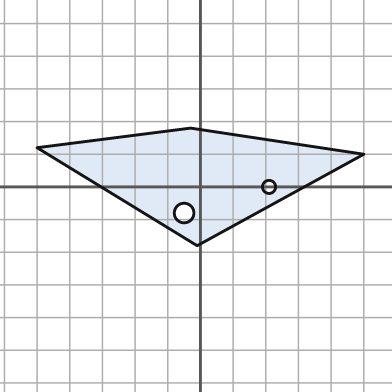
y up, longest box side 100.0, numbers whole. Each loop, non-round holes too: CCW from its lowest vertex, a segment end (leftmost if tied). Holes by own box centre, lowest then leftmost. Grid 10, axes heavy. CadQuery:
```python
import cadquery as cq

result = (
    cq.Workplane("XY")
    .moveTo(-1.0, -18.0)
    .lineTo(50.0, 10.0)
    .lineTo(-3.0, 18.0)
    .lineTo(-50.0, 12.0)
    .close()
    .moveTo(-5.0, -8.0)
    .circle(3.0)
    .moveTo(21.0, 0.0)
    .circle(2.0)
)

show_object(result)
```